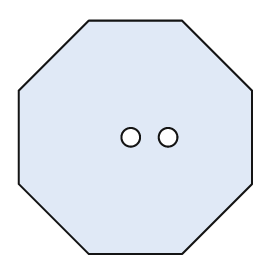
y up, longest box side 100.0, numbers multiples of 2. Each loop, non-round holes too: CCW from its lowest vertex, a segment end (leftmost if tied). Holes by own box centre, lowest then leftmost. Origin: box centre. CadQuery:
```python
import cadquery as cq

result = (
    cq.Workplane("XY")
    .moveTo(-20.0, -50.0)
    .lineTo(20.0, -50.0)
    .lineTo(50.0, -20.0)
    .lineTo(50.0, 20.0)
    .lineTo(20.0, 50.0)
    .lineTo(-20.0, 50.0)
    .lineTo(-50.0, 20.0)
    .lineTo(-50.0, -20.0)
    .close()
    .moveTo(-2.0, 0.0)
    .circle(4.0)
    .moveTo(14.0, 0.0)
    .circle(4.0)
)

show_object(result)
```